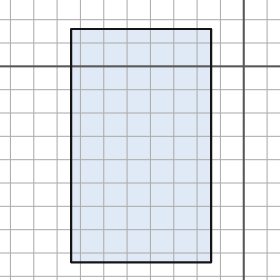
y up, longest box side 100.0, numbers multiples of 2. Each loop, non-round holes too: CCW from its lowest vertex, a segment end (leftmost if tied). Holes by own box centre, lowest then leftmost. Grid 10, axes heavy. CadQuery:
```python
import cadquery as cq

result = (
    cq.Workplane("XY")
    .moveTo(-74.0, -84.0)
    .lineTo(-14.0, -84.0)
    .lineTo(-14.0, 16.0)
    .lineTo(-74.0, 16.0)
    .close()
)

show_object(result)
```